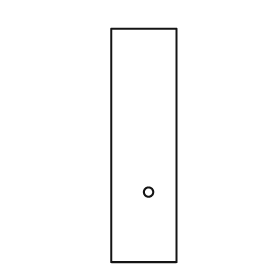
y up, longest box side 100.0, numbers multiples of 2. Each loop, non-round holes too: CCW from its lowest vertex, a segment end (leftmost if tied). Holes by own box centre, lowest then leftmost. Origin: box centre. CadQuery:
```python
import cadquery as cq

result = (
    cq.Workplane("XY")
    .moveTo(-14.0, -50.0)
    .lineTo(14.0, -50.0)
    .lineTo(14.0, 50.0)
    .lineTo(-14.0, 50.0)
    .close()
    .moveTo(2.0, -20.0)
    .circle(2.0)
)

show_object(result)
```